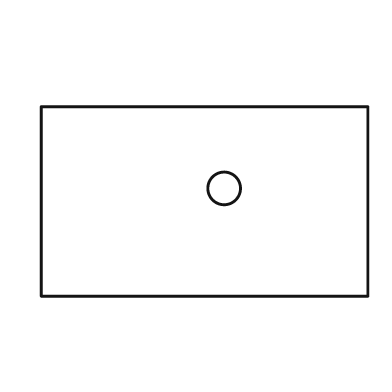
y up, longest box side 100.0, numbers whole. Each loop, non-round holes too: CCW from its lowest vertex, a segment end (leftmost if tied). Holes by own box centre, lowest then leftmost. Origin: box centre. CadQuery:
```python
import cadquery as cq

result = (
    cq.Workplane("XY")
    .moveTo(-50.0, -29.0)
    .lineTo(50.0, -29.0)
    .lineTo(50.0, 29.0)
    .lineTo(-50.0, 29.0)
    .close()
    .moveTo(6.0, 4.0)
    .circle(5.0)
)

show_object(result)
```